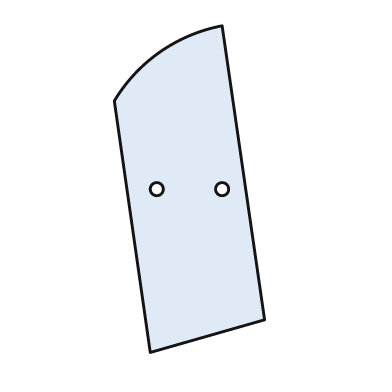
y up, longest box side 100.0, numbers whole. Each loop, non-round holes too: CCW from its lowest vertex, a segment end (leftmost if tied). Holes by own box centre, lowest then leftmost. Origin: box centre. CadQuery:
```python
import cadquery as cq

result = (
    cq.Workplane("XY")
    .moveTo(-12.0, -50.0)
    .lineTo(23.0, -40.0)
    .lineTo(10.0, 50.0)
    .threePointArc((-9.0, 42.0), (-23.0, 27.0))
    .close()
    .moveTo(-10.0, 0.0)
    .circle(2.0)
    .moveTo(10.0, 0.0)
    .circle(2.0)
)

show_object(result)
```